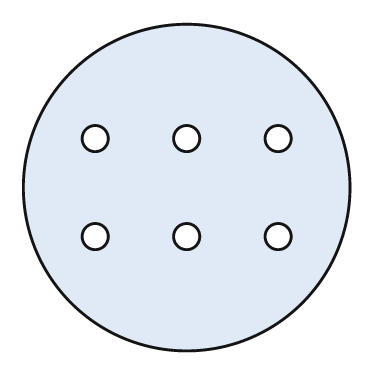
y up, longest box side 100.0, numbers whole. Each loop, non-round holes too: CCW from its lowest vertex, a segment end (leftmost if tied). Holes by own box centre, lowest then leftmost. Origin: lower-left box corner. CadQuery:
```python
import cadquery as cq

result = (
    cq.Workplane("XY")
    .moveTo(50.0, 50.0)
    .circle(50.0)
    .moveTo(22.0, 35.0)
    .circle(4.0)
    .moveTo(50.0, 35.0)
    .circle(4.0)
    .moveTo(78.0, 35.0)
    .circle(4.0)
    .moveTo(22.0, 65.0)
    .circle(4.0)
    .moveTo(50.0, 65.0)
    .circle(4.0)
    .moveTo(78.0, 65.0)
    .circle(4.0)
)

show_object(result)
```